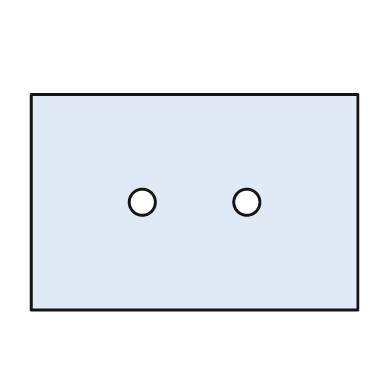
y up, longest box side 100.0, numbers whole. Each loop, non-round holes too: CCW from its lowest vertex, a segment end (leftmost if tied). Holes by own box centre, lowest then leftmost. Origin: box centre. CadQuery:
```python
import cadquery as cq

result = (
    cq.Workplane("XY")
    .moveTo(-50.0, -33.0)
    .lineTo(50.0, -33.0)
    .lineTo(50.0, 33.0)
    .lineTo(-50.0, 33.0)
    .close()
    .moveTo(-16.0, 0.0)
    .circle(4.0)
    .moveTo(16.0, 0.0)
    .circle(4.0)
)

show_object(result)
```